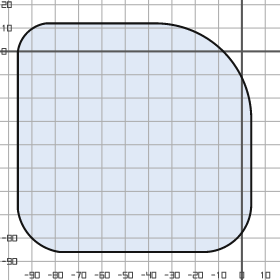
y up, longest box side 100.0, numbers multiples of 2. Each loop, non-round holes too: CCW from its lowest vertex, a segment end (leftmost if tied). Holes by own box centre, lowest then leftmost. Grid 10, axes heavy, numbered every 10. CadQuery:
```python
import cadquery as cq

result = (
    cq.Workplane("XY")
    .moveTo(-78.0, -86.0)
    .lineTo(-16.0, -86.0)
    .threePointArc((-2.0, -80.0), (4.0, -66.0))
    .lineTo(4.0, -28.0)
    .threePointArc((-8.0, 0.0), (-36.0, 12.0))
    .lineTo(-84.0, 12.0)
    .threePointArc((-92.0, 8.0), (-96.0, 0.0))
    .lineTo(-96.0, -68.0)
    .threePointArc((-90.0, -80.0), (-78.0, -86.0))
    .close()
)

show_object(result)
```